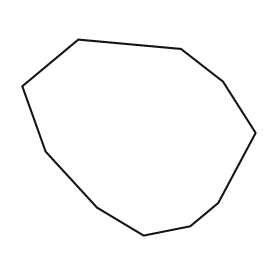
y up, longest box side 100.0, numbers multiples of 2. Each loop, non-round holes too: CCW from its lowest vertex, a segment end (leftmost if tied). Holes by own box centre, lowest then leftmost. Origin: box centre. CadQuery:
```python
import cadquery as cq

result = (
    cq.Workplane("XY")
    .moveTo(2.0, -42.0)
    .lineTo(22.0, -38.0)
    .lineTo(34.0, -28.0)
    .lineTo(50.0, 2.0)
    .lineTo(36.0, 24.0)
    .lineTo(18.0, 38.0)
    .lineTo(-26.0, 42.0)
    .lineTo(-50.0, 22.0)
    .lineTo(-40.0, -6.0)
    .lineTo(-18.0, -30.0)
    .close()
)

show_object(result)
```